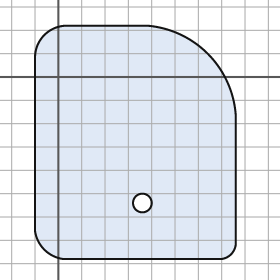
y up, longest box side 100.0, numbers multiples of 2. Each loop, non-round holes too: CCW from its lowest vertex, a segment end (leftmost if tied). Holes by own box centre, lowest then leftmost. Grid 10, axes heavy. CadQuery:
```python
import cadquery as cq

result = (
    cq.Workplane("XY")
    .moveTo(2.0, -78.0)
    .lineTo(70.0, -78.0)
    .threePointArc((74.0, -76.0), (76.0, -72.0))
    .lineTo(76.0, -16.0)
    .threePointArc((64.0, 10.0), (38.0, 22.0))
    .lineTo(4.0, 22.0)
    .threePointArc((-6.0, 18.0), (-10.0, 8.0))
    .lineTo(-10.0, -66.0)
    .threePointArc((-6.0, -74.0), (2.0, -78.0))
    .close()
    .moveTo(36.0, -54.0)
    .circle(4.0)
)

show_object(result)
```